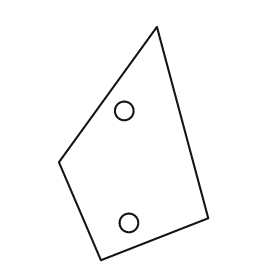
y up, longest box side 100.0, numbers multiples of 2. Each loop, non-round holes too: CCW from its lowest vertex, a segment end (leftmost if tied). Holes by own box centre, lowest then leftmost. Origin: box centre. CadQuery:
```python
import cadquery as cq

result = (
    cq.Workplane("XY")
    .moveTo(-14.0, -50.0)
    .lineTo(32.0, -32.0)
    .lineTo(10.0, 50.0)
    .lineTo(-32.0, -8.0)
    .close()
    .moveTo(-2.0, -34.0)
    .circle(4.0)
    .moveTo(-4.0, 14.0)
    .circle(4.0)
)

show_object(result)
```